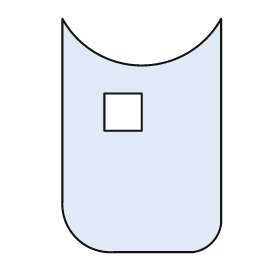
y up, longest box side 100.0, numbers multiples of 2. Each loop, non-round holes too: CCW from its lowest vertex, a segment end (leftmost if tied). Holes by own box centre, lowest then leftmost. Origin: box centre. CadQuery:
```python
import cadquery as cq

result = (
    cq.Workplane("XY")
    .moveTo(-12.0, -50.0)
    .lineTo(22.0, -50.0)
    .threePointArc((30.0, -46.0), (34.0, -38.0))
    .lineTo(34.0, 50.0)
    .threePointArc((0.0, 30.0), (-34.0, 50.0))
    .lineTo(-34.0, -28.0)
    .threePointArc((-28.0, -44.0), (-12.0, -50.0))
    .close()
    .moveTo(-16.0, 2.0)
    .lineTo(0.0, 2.0)
    .lineTo(0.0, 18.0)
    .lineTo(-16.0, 18.0)
    .close()
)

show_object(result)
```